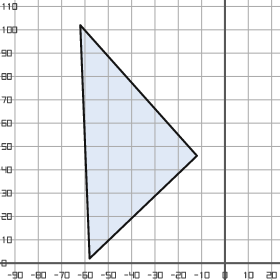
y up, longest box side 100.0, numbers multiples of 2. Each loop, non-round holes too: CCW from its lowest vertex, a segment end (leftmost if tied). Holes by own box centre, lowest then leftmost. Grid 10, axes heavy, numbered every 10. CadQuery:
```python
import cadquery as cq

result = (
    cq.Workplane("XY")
    .moveTo(-58.0, 2.0)
    .lineTo(-12.0, 46.0)
    .lineTo(-62.0, 102.0)
    .close()
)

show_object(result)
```